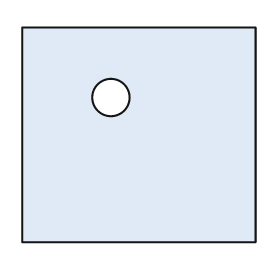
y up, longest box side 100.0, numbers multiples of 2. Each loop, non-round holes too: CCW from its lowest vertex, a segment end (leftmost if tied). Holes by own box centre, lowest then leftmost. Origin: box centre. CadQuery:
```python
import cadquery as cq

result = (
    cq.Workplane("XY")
    .moveTo(-50.0, -46.0)
    .lineTo(50.0, -46.0)
    .lineTo(50.0, 46.0)
    .lineTo(-50.0, 46.0)
    .close()
    .moveTo(-12.0, 16.0)
    .circle(8.0)
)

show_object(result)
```